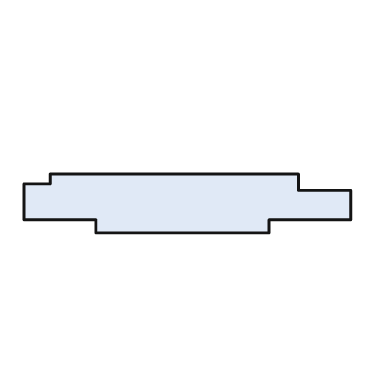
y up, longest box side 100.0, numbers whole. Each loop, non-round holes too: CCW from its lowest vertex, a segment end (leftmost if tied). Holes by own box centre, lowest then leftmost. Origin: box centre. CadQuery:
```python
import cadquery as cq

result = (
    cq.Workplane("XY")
    .moveTo(-28.0, -9.0)
    .lineTo(25.0, -9.0)
    .lineTo(25.0, -5.0)
    .lineTo(50.0, -5.0)
    .lineTo(50.0, 4.0)
    .lineTo(34.0, 4.0)
    .lineTo(34.0, 9.0)
    .lineTo(-42.0, 9.0)
    .lineTo(-42.0, 6.0)
    .lineTo(-50.0, 6.0)
    .lineTo(-50.0, -5.0)
    .lineTo(-28.0, -5.0)
    .close()
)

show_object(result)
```